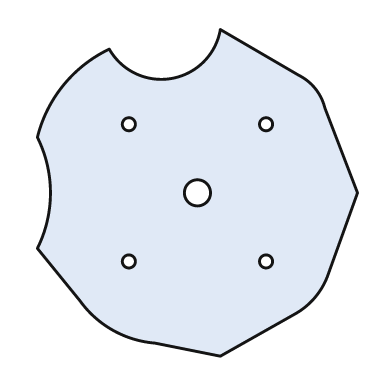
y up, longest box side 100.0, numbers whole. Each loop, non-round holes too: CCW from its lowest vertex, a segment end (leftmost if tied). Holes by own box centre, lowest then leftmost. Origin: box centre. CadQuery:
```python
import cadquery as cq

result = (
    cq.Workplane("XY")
    .moveTo(7.0, -50.0)
    .lineTo(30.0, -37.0)
    .threePointArc((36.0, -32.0), (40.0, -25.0))
    .lineTo(49.0, 0.0)
    .lineTo(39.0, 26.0)
    .threePointArc((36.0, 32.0), (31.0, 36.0))
    .lineTo(7.0, 50.0)
    .threePointArc((-8.0, 35.0), (-27.0, 44.0))
    .threePointArc((-41.0, 33.0), (-49.0, 17.0))
    .threePointArc((-45.0, 0.0), (-49.0, -17.0))
    .lineTo(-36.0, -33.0)
    .threePointArc((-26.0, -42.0), (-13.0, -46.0))
    .close()
    .moveTo(-21.0, -21.0)
    .circle(2.0)
    .moveTo(21.0, -21.0)
    .circle(2.0)
    .moveTo(0.0, 0.0)
    .circle(4.0)
    .moveTo(-21.0, 21.0)
    .circle(2.0)
    .moveTo(21.0, 21.0)
    .circle(2.0)
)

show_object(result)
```